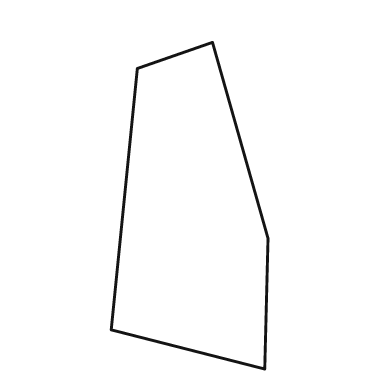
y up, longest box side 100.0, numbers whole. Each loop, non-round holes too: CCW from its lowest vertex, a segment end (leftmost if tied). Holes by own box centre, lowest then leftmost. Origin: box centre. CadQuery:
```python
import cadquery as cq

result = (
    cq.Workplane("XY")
    .moveTo(23.0, -50.0)
    .lineTo(24.0, -10.0)
    .lineTo(7.0, 50.0)
    .lineTo(-16.0, 42.0)
    .lineTo(-24.0, -38.0)
    .close()
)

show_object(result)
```